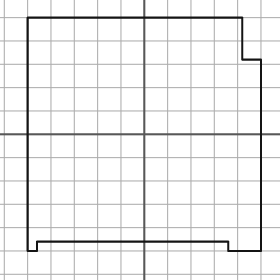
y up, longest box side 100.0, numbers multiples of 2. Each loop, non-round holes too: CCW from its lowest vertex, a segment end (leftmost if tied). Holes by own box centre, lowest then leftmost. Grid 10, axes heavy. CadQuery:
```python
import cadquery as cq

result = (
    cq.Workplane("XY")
    .moveTo(-50.0, -50.0)
    .lineTo(-46.0, -50.0)
    .lineTo(-46.0, -46.0)
    .lineTo(36.0, -46.0)
    .lineTo(36.0, -50.0)
    .lineTo(50.0, -50.0)
    .lineTo(50.0, 32.0)
    .lineTo(42.0, 32.0)
    .lineTo(42.0, 50.0)
    .lineTo(-50.0, 50.0)
    .close()
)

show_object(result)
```